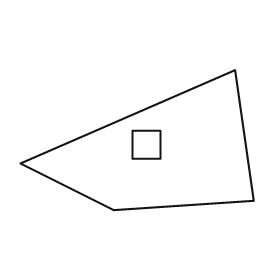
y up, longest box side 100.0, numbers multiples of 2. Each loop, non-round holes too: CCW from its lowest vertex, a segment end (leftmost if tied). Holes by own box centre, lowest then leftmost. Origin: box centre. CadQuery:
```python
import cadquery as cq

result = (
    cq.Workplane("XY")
    .moveTo(-10.0, -30.0)
    .lineTo(50.0, -26.0)
    .lineTo(42.0, 30.0)
    .lineTo(-50.0, -10.0)
    .close()
    .moveTo(-2.0, -8.0)
    .lineTo(10.0, -8.0)
    .lineTo(10.0, 4.0)
    .lineTo(-2.0, 4.0)
    .close()
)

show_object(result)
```